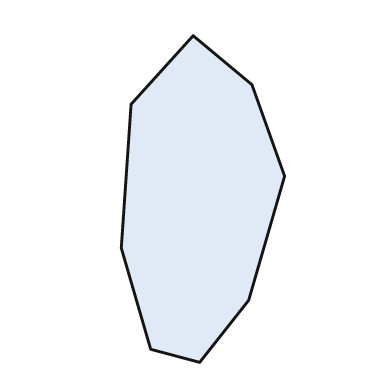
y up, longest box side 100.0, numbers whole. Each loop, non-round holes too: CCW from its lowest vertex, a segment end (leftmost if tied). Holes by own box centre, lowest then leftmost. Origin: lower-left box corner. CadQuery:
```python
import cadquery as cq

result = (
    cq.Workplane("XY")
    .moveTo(24.0, 0.0)
    .lineTo(39.0, 19.0)
    .lineTo(50.0, 57.0)
    .lineTo(40.0, 85.0)
    .lineTo(22.0, 100.0)
    .lineTo(3.0, 79.0)
    .lineTo(0.0, 35.0)
    .lineTo(9.0, 4.0)
    .close()
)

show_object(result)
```